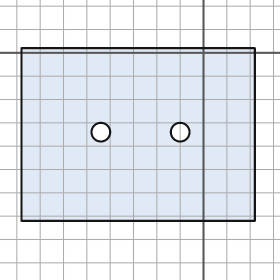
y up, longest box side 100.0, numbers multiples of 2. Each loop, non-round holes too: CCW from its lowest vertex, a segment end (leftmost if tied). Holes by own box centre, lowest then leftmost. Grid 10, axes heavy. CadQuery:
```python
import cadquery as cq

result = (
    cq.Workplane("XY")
    .moveTo(-78.0, -72.0)
    .lineTo(22.0, -72.0)
    .lineTo(22.0, 2.0)
    .lineTo(-78.0, 2.0)
    .close()
    .moveTo(-44.0, -34.0)
    .circle(4.0)
    .moveTo(-10.0, -34.0)
    .circle(4.0)
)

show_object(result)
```